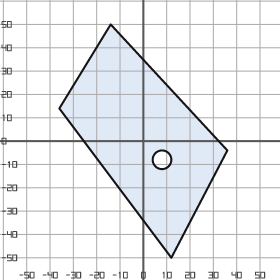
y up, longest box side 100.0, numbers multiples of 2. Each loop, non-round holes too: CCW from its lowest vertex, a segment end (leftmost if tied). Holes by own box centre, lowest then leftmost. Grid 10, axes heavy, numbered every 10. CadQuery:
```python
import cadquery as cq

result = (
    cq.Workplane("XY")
    .moveTo(12.0, -50.0)
    .lineTo(36.0, -4.0)
    .lineTo(-14.0, 50.0)
    .lineTo(-36.0, 14.0)
    .close()
    .moveTo(8.0, -8.0)
    .circle(4.0)
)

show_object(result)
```